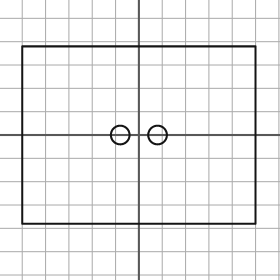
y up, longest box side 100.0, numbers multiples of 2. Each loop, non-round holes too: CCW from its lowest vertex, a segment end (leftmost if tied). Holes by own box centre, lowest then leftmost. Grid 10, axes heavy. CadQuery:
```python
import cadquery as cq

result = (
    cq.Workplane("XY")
    .moveTo(-50.0, -38.0)
    .lineTo(50.0, -38.0)
    .lineTo(50.0, 38.0)
    .lineTo(-50.0, 38.0)
    .close()
    .moveTo(-8.0, 0.0)
    .circle(4.0)
    .moveTo(8.0, 0.0)
    .circle(4.0)
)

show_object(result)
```